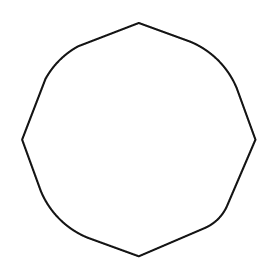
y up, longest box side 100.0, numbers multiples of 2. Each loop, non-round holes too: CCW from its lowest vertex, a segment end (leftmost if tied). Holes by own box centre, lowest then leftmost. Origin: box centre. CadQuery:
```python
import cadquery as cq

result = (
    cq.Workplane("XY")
    .moveTo(0.0, -50.0)
    .lineTo(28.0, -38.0)
    .threePointArc((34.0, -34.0), (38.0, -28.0))
    .lineTo(50.0, 0.0)
    .lineTo(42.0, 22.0)
    .threePointArc((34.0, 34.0), (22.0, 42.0))
    .lineTo(0.0, 50.0)
    .lineTo(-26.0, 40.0)
    .threePointArc((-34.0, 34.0), (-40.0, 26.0))
    .lineTo(-50.0, 0.0)
    .lineTo(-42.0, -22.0)
    .threePointArc((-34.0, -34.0), (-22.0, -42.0))
    .close()
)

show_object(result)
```